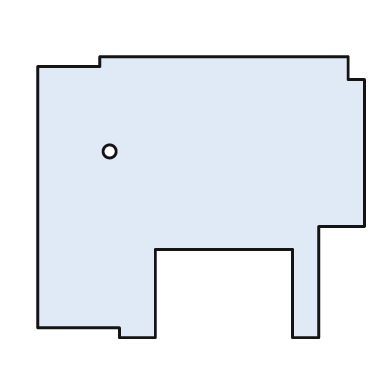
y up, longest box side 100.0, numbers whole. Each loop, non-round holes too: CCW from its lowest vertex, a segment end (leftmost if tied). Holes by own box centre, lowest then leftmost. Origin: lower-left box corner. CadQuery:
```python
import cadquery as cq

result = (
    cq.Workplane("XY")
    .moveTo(25.0, 0.0)
    .lineTo(36.0, 0.0)
    .lineTo(36.0, 27.0)
    .lineTo(78.0, 27.0)
    .lineTo(78.0, 0.0)
    .lineTo(86.0, 0.0)
    .lineTo(86.0, 34.0)
    .lineTo(100.0, 34.0)
    .lineTo(100.0, 79.0)
    .lineTo(95.0, 79.0)
    .lineTo(95.0, 86.0)
    .lineTo(19.0, 86.0)
    .lineTo(19.0, 83.0)
    .lineTo(0.0, 83.0)
    .lineTo(0.0, 3.0)
    .lineTo(25.0, 3.0)
    .close()
    .moveTo(22.0, 57.0)
    .circle(2.0)
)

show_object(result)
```